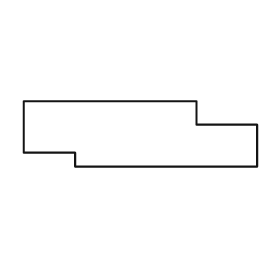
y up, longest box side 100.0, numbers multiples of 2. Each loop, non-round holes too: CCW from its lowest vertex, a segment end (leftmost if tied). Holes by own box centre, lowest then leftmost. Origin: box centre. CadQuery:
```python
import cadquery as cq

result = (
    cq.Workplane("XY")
    .moveTo(-28.0, -14.0)
    .lineTo(50.0, -14.0)
    .lineTo(50.0, 4.0)
    .lineTo(24.0, 4.0)
    .lineTo(24.0, 14.0)
    .lineTo(-50.0, 14.0)
    .lineTo(-50.0, -8.0)
    .lineTo(-28.0, -8.0)
    .close()
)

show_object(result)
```